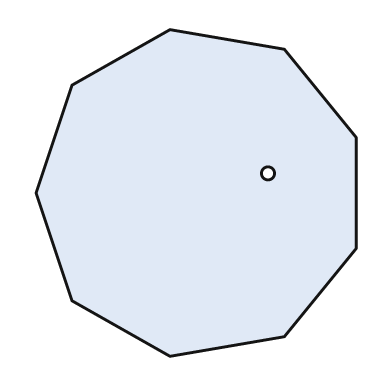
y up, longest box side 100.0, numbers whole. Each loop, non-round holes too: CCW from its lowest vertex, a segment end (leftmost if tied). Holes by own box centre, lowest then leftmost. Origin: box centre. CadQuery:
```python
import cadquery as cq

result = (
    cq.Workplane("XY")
    .moveTo(-8.0, -50.0)
    .lineTo(27.0, -44.0)
    .lineTo(49.0, -17.0)
    .lineTo(49.0, 17.0)
    .lineTo(27.0, 44.0)
    .lineTo(-8.0, 50.0)
    .lineTo(-38.0, 33.0)
    .lineTo(-49.0, 0.0)
    .lineTo(-38.0, -33.0)
    .close()
    .moveTo(22.0, 6.0)
    .circle(2.0)
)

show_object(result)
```